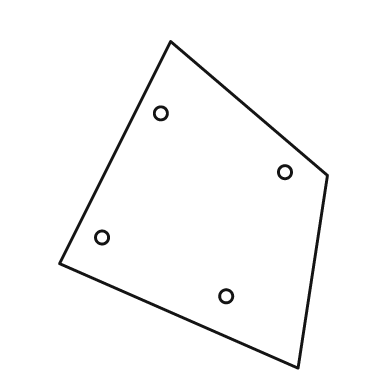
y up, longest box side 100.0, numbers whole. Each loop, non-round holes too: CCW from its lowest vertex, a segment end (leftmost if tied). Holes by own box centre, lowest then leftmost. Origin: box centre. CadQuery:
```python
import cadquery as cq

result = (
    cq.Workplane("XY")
    .moveTo(32.0, -50.0)
    .lineTo(41.0, 9.0)
    .lineTo(-7.0, 50.0)
    .lineTo(-41.0, -18.0)
    .close()
    .moveTo(10.0, -28.0)
    .circle(2.0)
    .moveTo(-28.0, -10.0)
    .circle(2.0)
    .moveTo(28.0, 10.0)
    .circle(2.0)
    .moveTo(-10.0, 28.0)
    .circle(2.0)
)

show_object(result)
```